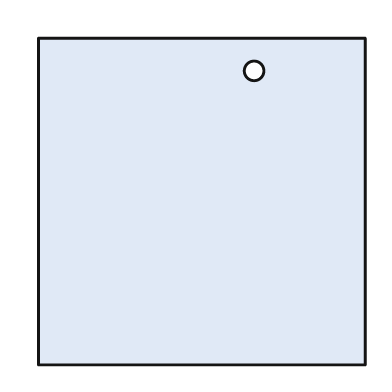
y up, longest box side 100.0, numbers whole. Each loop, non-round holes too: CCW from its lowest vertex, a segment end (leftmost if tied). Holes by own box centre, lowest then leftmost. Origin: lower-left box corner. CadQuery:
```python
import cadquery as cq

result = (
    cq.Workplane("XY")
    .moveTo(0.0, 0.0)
    .lineTo(100.0, 0.0)
    .lineTo(100.0, 100.0)
    .lineTo(0.0, 100.0)
    .close()
    .moveTo(66.0, 90.0)
    .circle(3.0)
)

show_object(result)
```